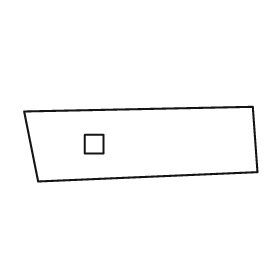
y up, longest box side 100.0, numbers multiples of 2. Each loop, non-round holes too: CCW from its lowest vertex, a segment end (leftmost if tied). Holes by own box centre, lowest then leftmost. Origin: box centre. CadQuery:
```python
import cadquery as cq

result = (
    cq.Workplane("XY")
    .moveTo(-44.0, -16.0)
    .lineTo(50.0, -12.0)
    .lineTo(48.0, 16.0)
    .lineTo(-50.0, 14.0)
    .close()
    .moveTo(-24.0, -4.0)
    .lineTo(-16.0, -4.0)
    .lineTo(-16.0, 4.0)
    .lineTo(-24.0, 4.0)
    .close()
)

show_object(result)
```